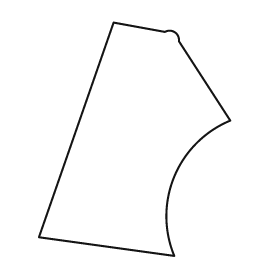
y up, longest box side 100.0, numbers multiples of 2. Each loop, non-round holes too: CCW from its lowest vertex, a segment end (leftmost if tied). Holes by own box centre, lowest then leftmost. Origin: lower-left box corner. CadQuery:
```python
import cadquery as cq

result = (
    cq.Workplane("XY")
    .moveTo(58.0, 0.0)
    .threePointArc((58.0, 34.0), (82.0, 58.0))
    .lineTo(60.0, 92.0)
    .threePointArc((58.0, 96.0), (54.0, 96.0))
    .lineTo(32.0, 100.0)
    .lineTo(0.0, 8.0)
    .close()
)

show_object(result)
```